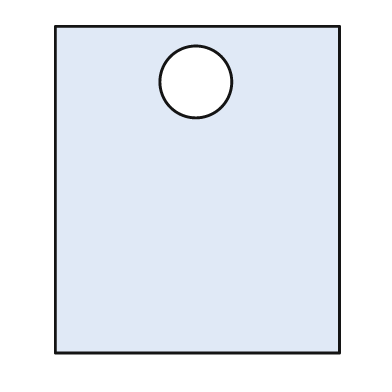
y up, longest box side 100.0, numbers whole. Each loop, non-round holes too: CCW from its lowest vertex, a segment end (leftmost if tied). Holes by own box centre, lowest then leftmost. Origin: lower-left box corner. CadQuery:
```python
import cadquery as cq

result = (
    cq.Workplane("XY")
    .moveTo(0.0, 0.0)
    .lineTo(87.0, 0.0)
    .lineTo(87.0, 100.0)
    .lineTo(0.0, 100.0)
    .close()
    .moveTo(43.0, 83.0)
    .circle(11.0)
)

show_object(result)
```